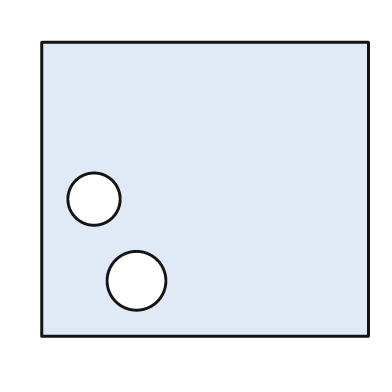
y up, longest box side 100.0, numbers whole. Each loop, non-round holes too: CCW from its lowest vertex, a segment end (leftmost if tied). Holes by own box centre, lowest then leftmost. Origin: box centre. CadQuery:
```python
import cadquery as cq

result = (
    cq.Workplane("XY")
    .moveTo(-50.0, -45.0)
    .lineTo(50.0, -45.0)
    .lineTo(50.0, 45.0)
    .lineTo(-50.0, 45.0)
    .close()
    .moveTo(-21.0, -28.0)
    .circle(9.0)
    .moveTo(-34.0, -3.0)
    .circle(8.0)
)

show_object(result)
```